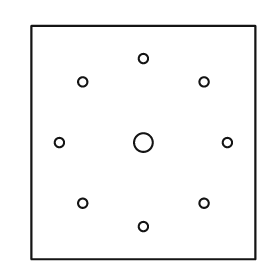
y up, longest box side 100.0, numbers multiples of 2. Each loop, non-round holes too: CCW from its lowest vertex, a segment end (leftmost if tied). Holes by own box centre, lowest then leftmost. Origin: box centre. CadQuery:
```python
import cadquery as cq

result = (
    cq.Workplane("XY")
    .moveTo(-48.0, -50.0)
    .lineTo(48.0, -50.0)
    .lineTo(48.0, 50.0)
    .lineTo(-48.0, 50.0)
    .close()
    .moveTo(0.0, -36.0)
    .circle(2.0)
    .moveTo(-26.0, -26.0)
    .circle(2.0)
    .moveTo(26.0, -26.0)
    .circle(2.0)
    .moveTo(-36.0, 0.0)
    .circle(2.0)
    .moveTo(0.0, 0.0)
    .circle(4.0)
    .moveTo(36.0, 0.0)
    .circle(2.0)
    .moveTo(-26.0, 26.0)
    .circle(2.0)
    .moveTo(26.0, 26.0)
    .circle(2.0)
    .moveTo(0.0, 36.0)
    .circle(2.0)
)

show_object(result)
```